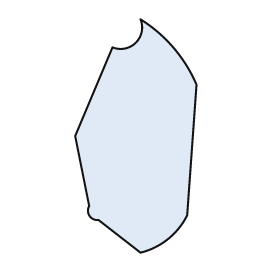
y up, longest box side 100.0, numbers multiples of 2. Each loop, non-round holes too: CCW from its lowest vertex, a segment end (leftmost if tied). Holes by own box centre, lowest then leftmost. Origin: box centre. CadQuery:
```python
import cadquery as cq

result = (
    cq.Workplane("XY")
    .moveTo(2.0, -50.0)
    .threePointArc((14.0, -44.0), (22.0, -34.0))
    .lineTo(26.0, 22.0)
    .threePointArc((16.0, 38.0), (2.0, 50.0))
    .threePointArc((0.0, 40.0), (-10.0, 38.0))
    .lineTo(-26.0, 0.0)
    .lineTo(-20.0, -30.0)
    .threePointArc((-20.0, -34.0), (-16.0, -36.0))
    .close()
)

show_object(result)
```